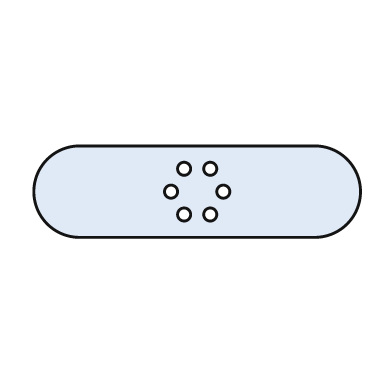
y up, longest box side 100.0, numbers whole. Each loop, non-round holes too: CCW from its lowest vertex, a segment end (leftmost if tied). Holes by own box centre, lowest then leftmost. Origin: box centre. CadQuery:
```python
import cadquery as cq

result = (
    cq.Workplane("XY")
    .moveTo(-36.0, -14.0)
    .lineTo(36.0, -14.0)
    .threePointArc((50.0, 0.0), (36.0, 14.0))
    .lineTo(-36.0, 14.0)
    .threePointArc((-50.0, 0.0), (-36.0, -14.0))
    .close()
    .moveTo(-4.0, -7.0)
    .circle(2.0)
    .moveTo(4.0, -7.0)
    .circle(2.0)
    .moveTo(-8.0, 0.0)
    .circle(2.0)
    .moveTo(8.0, 0.0)
    .circle(2.0)
    .moveTo(-4.0, 7.0)
    .circle(2.0)
    .moveTo(4.0, 7.0)
    .circle(2.0)
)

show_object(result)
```